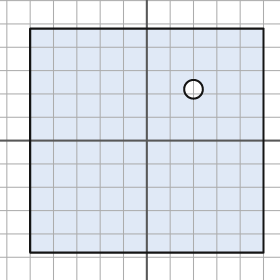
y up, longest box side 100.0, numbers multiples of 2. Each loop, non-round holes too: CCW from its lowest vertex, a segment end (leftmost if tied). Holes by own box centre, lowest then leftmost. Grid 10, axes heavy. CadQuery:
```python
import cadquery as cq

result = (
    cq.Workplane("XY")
    .moveTo(-50.0, -48.0)
    .lineTo(50.0, -48.0)
    .lineTo(50.0, 48.0)
    .lineTo(-50.0, 48.0)
    .close()
    .moveTo(20.0, 22.0)
    .circle(4.0)
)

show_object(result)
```